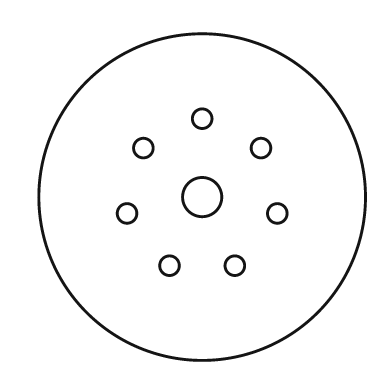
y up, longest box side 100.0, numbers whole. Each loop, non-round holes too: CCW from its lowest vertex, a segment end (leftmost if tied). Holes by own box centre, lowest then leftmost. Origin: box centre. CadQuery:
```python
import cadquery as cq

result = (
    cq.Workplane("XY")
    .moveTo(0.0, 0.0)
    .circle(50.0)
    .moveTo(-10.0, -21.0)
    .circle(3.0)
    .moveTo(10.0, -21.0)
    .circle(3.0)
    .moveTo(-23.0, -5.0)
    .circle(3.0)
    .moveTo(23.0, -5.0)
    .circle(3.0)
    .moveTo(0.0, 0.0)
    .circle(6.0)
    .moveTo(-18.0, 15.0)
    .circle(3.0)
    .moveTo(18.0, 15.0)
    .circle(3.0)
    .moveTo(0.0, 24.0)
    .circle(3.0)
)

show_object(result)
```